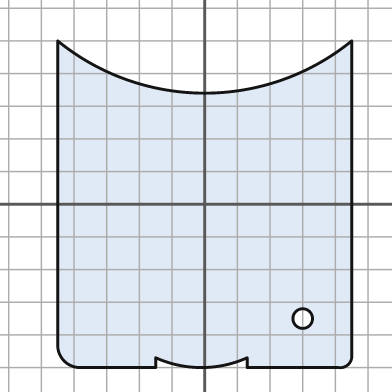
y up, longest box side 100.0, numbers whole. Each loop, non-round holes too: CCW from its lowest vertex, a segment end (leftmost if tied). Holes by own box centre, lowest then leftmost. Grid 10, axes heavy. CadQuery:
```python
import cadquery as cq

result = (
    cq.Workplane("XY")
    .moveTo(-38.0, -50.0)
    .lineTo(-15.0, -50.0)
    .lineTo(-15.0, -47.0)
    .threePointArc((-1.0, -50.0), (13.0, -47.0))
    .lineTo(13.0, -50.0)
    .lineTo(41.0, -50.0)
    .threePointArc((44.0, -49.0), (45.0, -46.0))
    .lineTo(45.0, 50.0)
    .threePointArc((0.0, 34.0), (-45.0, 50.0))
    .lineTo(-45.0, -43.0)
    .threePointArc((-43.0, -48.0), (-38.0, -50.0))
    .close()
    .moveTo(30.0, -35.0)
    .circle(3.0)
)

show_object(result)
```